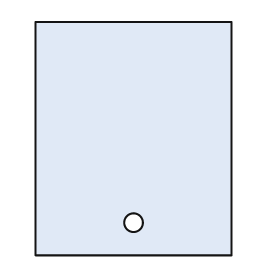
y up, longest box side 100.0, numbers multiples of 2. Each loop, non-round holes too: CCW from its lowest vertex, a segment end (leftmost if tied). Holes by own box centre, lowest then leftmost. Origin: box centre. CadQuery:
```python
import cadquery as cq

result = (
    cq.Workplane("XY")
    .moveTo(-42.0, -50.0)
    .lineTo(42.0, -50.0)
    .lineTo(42.0, 50.0)
    .lineTo(-42.0, 50.0)
    .close()
    .moveTo(0.0, -36.0)
    .circle(4.0)
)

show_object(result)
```